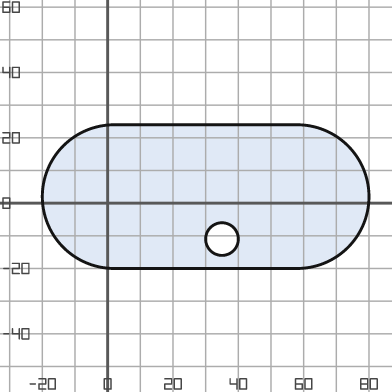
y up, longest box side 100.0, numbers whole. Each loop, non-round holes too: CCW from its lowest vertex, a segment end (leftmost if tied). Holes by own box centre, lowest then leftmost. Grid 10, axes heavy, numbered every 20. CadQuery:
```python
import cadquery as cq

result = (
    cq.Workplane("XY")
    .moveTo(2.0, -20.0)
    .lineTo(58.0, -20.0)
    .threePointArc((80.0, 2.0), (58.0, 24.0))
    .lineTo(2.0, 24.0)
    .threePointArc((-20.0, 2.0), (2.0, -20.0))
    .close()
    .moveTo(35.0, -11.0)
    .circle(5.0)
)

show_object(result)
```